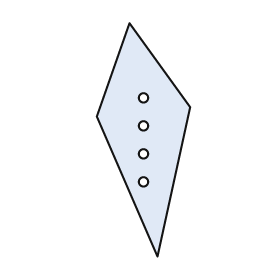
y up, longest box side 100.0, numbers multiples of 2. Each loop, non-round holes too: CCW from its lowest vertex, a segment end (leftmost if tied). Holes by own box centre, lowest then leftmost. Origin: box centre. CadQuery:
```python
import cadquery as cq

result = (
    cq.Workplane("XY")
    .moveTo(6.0, -50.0)
    .lineTo(20.0, 14.0)
    .lineTo(-6.0, 50.0)
    .lineTo(-20.0, 10.0)
    .close()
    .moveTo(0.0, -18.0)
    .circle(2.0)
    .moveTo(0.0, -6.0)
    .circle(2.0)
    .moveTo(0.0, 6.0)
    .circle(2.0)
    .moveTo(0.0, 18.0)
    .circle(2.0)
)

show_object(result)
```